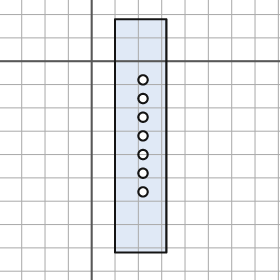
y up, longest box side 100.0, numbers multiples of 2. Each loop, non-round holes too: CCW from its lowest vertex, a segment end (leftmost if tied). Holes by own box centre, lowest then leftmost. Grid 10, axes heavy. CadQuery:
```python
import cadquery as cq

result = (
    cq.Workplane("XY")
    .moveTo(10.0, -82.0)
    .lineTo(32.0, -82.0)
    .lineTo(32.0, 18.0)
    .lineTo(10.0, 18.0)
    .close()
    .moveTo(22.0, -56.0)
    .circle(2.0)
    .moveTo(22.0, -48.0)
    .circle(2.0)
    .moveTo(22.0, -40.0)
    .circle(2.0)
    .moveTo(22.0, -32.0)
    .circle(2.0)
    .moveTo(22.0, -24.0)
    .circle(2.0)
    .moveTo(22.0, -16.0)
    .circle(2.0)
    .moveTo(22.0, -8.0)
    .circle(2.0)
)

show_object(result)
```